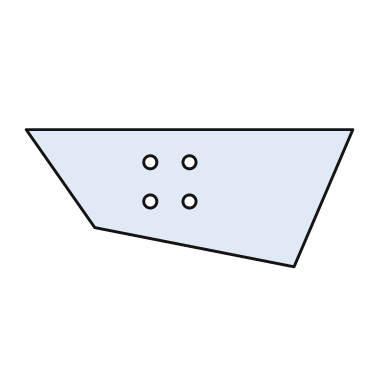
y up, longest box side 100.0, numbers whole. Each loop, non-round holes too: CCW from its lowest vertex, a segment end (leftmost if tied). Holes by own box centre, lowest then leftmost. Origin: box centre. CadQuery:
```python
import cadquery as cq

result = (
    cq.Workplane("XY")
    .moveTo(32.0, -21.0)
    .lineTo(50.0, 21.0)
    .lineTo(-50.0, 21.0)
    .lineTo(-29.0, -9.0)
    .close()
    .moveTo(-12.0, -1.0)
    .circle(2.0)
    .moveTo(0.0, -1.0)
    .circle(2.0)
    .moveTo(-12.0, 11.0)
    .circle(2.0)
    .moveTo(0.0, 11.0)
    .circle(2.0)
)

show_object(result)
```